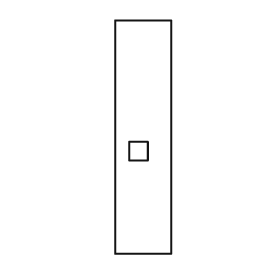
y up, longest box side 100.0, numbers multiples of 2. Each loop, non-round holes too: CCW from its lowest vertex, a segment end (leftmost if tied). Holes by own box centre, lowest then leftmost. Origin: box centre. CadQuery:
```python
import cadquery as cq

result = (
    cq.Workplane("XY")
    .moveTo(-12.0, -50.0)
    .lineTo(12.0, -50.0)
    .lineTo(12.0, 50.0)
    .lineTo(-12.0, 50.0)
    .close()
    .moveTo(-6.0, -10.0)
    .lineTo(2.0, -10.0)
    .lineTo(2.0, -2.0)
    .lineTo(-6.0, -2.0)
    .close()
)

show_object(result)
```